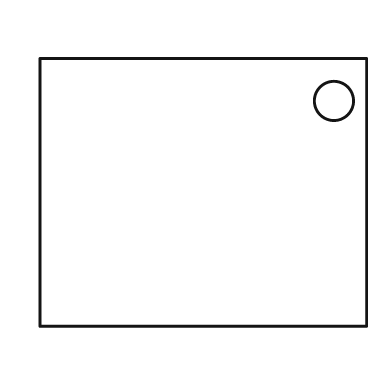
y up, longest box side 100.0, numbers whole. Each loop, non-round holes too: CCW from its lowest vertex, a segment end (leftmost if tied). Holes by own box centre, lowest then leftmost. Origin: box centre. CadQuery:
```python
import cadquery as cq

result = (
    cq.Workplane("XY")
    .moveTo(-50.0, -41.0)
    .lineTo(50.0, -41.0)
    .lineTo(50.0, 41.0)
    .lineTo(-50.0, 41.0)
    .close()
    .moveTo(40.0, 28.0)
    .circle(6.0)
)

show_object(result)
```